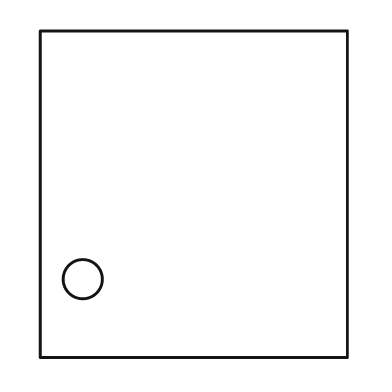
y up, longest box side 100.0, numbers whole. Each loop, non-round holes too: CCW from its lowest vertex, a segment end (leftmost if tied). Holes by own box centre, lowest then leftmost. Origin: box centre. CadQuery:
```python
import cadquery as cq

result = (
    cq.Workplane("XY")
    .moveTo(-47.0, -50.0)
    .lineTo(47.0, -50.0)
    .lineTo(47.0, 50.0)
    .lineTo(-47.0, 50.0)
    .close()
    .moveTo(-34.0, -26.0)
    .circle(6.0)
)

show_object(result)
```